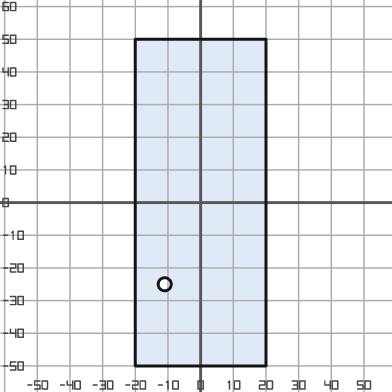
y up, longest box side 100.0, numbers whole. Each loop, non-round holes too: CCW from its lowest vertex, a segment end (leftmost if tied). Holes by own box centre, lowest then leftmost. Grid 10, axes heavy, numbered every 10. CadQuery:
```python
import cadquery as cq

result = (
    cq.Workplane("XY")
    .moveTo(-20.0, -50.0)
    .lineTo(20.0, -50.0)
    .lineTo(20.0, 50.0)
    .lineTo(-20.0, 50.0)
    .close()
    .moveTo(-11.0, -25.0)
    .circle(2.0)
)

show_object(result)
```